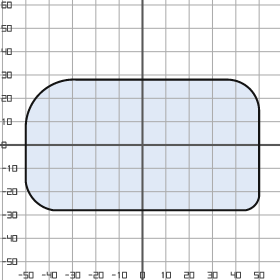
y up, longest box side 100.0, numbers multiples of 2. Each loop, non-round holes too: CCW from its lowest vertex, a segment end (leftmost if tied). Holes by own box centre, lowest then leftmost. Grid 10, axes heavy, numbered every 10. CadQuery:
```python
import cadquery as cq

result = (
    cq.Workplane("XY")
    .moveTo(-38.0, -28.0)
    .lineTo(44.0, -28.0)
    .threePointArc((48.0, -26.0), (50.0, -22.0))
    .lineTo(50.0, 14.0)
    .threePointArc((46.0, 24.0), (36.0, 28.0))
    .lineTo(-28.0, 28.0)
    .threePointArc((-44.0, 22.0), (-50.0, 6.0))
    .lineTo(-50.0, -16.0)
    .threePointArc((-46.0, -24.0), (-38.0, -28.0))
    .close()
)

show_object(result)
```